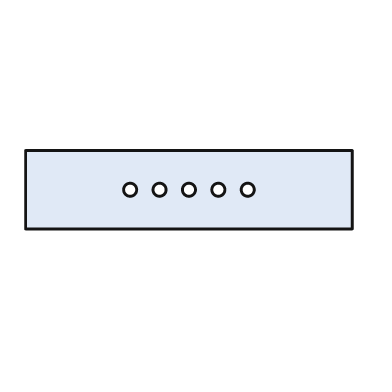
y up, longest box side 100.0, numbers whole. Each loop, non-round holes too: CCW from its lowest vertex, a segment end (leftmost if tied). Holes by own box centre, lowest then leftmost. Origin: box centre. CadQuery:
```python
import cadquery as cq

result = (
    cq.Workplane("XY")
    .moveTo(-50.0, -12.0)
    .lineTo(50.0, -12.0)
    .lineTo(50.0, 12.0)
    .lineTo(-50.0, 12.0)
    .close()
    .moveTo(-18.0, 0.0)
    .circle(2.0)
    .moveTo(-9.0, 0.0)
    .circle(2.0)
    .moveTo(0.0, 0.0)
    .circle(2.0)
    .moveTo(9.0, 0.0)
    .circle(2.0)
    .moveTo(18.0, 0.0)
    .circle(2.0)
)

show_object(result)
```